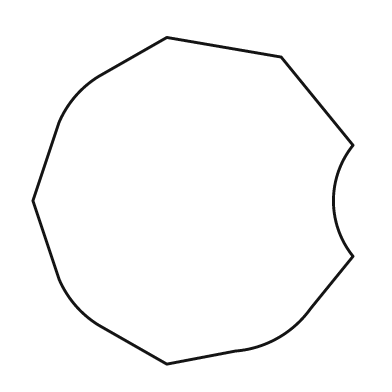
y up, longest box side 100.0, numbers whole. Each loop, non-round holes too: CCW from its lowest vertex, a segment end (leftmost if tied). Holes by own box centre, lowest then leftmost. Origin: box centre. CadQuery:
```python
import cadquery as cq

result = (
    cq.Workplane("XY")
    .moveTo(-8.0, -50.0)
    .lineTo(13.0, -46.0)
    .threePointArc((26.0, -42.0), (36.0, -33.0))
    .lineTo(49.0, -17.0)
    .threePointArc((43.0, 0.0), (49.0, 17.0))
    .lineTo(27.0, 44.0)
    .lineTo(-8.0, 50.0)
    .lineTo(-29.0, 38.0)
    .threePointArc((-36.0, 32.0), (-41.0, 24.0))
    .lineTo(-49.0, 0.0)
    .lineTo(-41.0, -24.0)
    .threePointArc((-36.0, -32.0), (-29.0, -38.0))
    .close()
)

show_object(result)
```